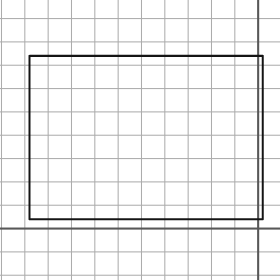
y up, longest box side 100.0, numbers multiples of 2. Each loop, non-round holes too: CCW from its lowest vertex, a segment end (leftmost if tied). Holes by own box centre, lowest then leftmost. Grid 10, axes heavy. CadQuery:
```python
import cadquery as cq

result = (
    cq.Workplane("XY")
    .moveTo(-98.0, 4.0)
    .lineTo(2.0, 4.0)
    .lineTo(2.0, 74.0)
    .lineTo(-98.0, 74.0)
    .close()
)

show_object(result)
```